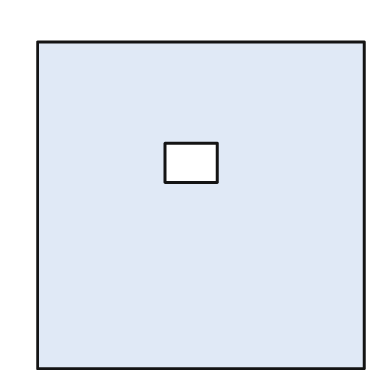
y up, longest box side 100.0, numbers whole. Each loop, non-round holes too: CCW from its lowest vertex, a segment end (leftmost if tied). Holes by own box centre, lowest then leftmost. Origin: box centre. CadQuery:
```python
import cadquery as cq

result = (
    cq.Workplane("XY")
    .moveTo(-50.0, -50.0)
    .lineTo(50.0, -50.0)
    .lineTo(50.0, 50.0)
    .lineTo(-50.0, 50.0)
    .close()
    .moveTo(-11.0, 7.0)
    .lineTo(5.0, 7.0)
    .lineTo(5.0, 19.0)
    .lineTo(-11.0, 19.0)
    .close()
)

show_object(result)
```